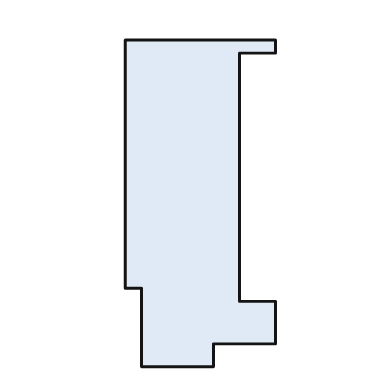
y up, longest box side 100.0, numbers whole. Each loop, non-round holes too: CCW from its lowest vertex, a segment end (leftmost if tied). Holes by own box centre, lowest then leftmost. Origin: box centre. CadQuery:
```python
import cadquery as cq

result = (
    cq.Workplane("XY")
    .moveTo(-18.0, -50.0)
    .lineTo(4.0, -50.0)
    .lineTo(4.0, -43.0)
    .lineTo(23.0, -43.0)
    .lineTo(23.0, -30.0)
    .lineTo(12.0, -30.0)
    .lineTo(12.0, 46.0)
    .lineTo(23.0, 46.0)
    .lineTo(23.0, 50.0)
    .lineTo(-23.0, 50.0)
    .lineTo(-23.0, -26.0)
    .lineTo(-18.0, -26.0)
    .close()
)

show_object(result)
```